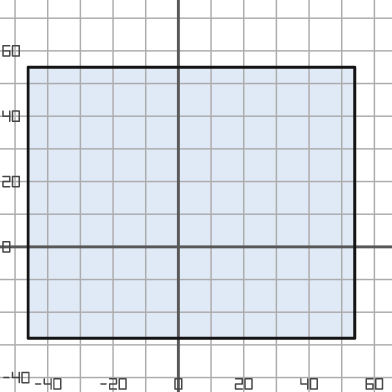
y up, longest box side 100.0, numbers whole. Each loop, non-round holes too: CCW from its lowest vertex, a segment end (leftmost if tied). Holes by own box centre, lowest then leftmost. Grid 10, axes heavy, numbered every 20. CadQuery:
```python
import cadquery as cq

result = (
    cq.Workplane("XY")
    .moveTo(-46.0, -28.0)
    .lineTo(54.0, -28.0)
    .lineTo(54.0, 55.0)
    .lineTo(-46.0, 55.0)
    .close()
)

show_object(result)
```